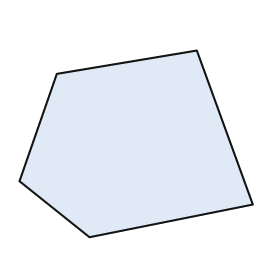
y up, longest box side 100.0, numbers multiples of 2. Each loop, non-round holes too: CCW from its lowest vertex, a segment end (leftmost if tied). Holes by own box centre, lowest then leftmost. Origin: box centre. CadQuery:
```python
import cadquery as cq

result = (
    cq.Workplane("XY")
    .moveTo(-20.0, -40.0)
    .lineTo(50.0, -26.0)
    .lineTo(26.0, 40.0)
    .lineTo(-34.0, 30.0)
    .lineTo(-50.0, -16.0)
    .close()
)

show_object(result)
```